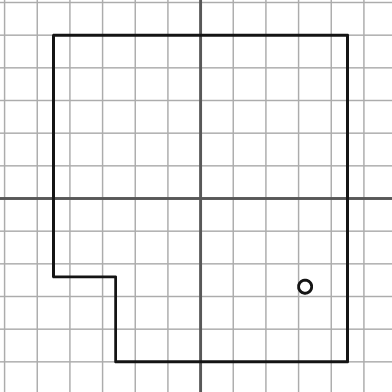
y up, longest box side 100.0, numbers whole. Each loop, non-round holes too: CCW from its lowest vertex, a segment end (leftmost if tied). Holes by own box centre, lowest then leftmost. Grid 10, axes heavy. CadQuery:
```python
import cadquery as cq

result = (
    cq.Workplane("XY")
    .moveTo(-26.0, -50.0)
    .lineTo(45.0, -50.0)
    .lineTo(45.0, 50.0)
    .lineTo(-45.0, 50.0)
    .lineTo(-45.0, -24.0)
    .lineTo(-26.0, -24.0)
    .close()
    .moveTo(32.0, -27.0)
    .circle(2.0)
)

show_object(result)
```